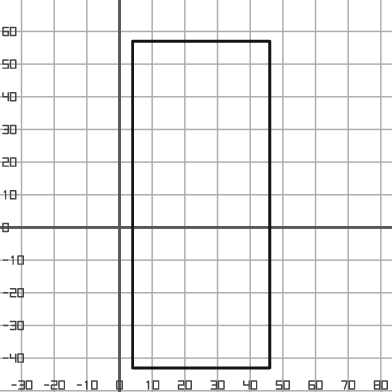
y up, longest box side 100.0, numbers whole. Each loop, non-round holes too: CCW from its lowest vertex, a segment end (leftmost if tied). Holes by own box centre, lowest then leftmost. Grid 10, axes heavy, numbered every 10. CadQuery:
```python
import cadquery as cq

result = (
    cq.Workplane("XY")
    .moveTo(4.0, -43.0)
    .lineTo(46.0, -43.0)
    .lineTo(46.0, 57.0)
    .lineTo(4.0, 57.0)
    .close()
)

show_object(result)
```